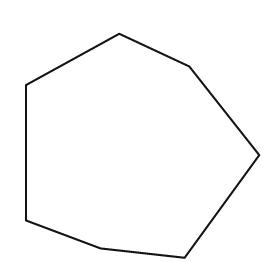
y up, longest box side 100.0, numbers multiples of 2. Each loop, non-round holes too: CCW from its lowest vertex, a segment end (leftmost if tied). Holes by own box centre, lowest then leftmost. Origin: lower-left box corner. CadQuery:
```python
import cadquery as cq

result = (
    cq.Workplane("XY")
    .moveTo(68.0, 0.0)
    .lineTo(100.0, 44.0)
    .lineTo(70.0, 82.0)
    .lineTo(40.0, 96.0)
    .lineTo(0.0, 74.0)
    .lineTo(0.0, 16.0)
    .lineTo(32.0, 4.0)
    .close()
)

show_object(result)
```